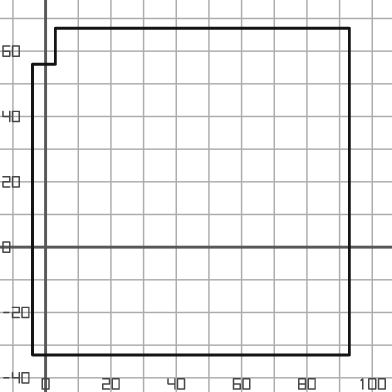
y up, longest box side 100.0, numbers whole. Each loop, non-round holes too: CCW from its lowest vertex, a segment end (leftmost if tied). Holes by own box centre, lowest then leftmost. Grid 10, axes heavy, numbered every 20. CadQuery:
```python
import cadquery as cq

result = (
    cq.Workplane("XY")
    .moveTo(-4.0, -33.0)
    .lineTo(93.0, -33.0)
    .lineTo(93.0, 67.0)
    .lineTo(3.0, 67.0)
    .lineTo(3.0, 56.0)
    .lineTo(-4.0, 56.0)
    .close()
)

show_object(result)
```